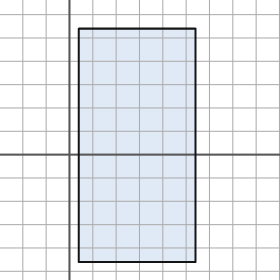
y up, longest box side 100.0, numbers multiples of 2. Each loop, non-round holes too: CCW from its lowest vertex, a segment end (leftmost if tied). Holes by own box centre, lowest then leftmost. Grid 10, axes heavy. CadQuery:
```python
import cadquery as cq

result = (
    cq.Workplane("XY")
    .moveTo(4.0, -46.0)
    .lineTo(54.0, -46.0)
    .lineTo(54.0, 54.0)
    .lineTo(4.0, 54.0)
    .close()
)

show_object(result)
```